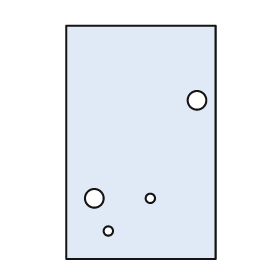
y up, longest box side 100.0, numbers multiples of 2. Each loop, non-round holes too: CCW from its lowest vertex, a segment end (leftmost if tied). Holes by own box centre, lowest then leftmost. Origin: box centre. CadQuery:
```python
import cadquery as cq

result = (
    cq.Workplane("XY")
    .moveTo(-32.0, -50.0)
    .lineTo(32.0, -50.0)
    .lineTo(32.0, 50.0)
    .lineTo(-32.0, 50.0)
    .close()
    .moveTo(-14.0, -38.0)
    .circle(2.0)
    .moveTo(-20.0, -24.0)
    .circle(4.0)
    .moveTo(4.0, -24.0)
    .circle(2.0)
    .moveTo(24.0, 18.0)
    .circle(4.0)
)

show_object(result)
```